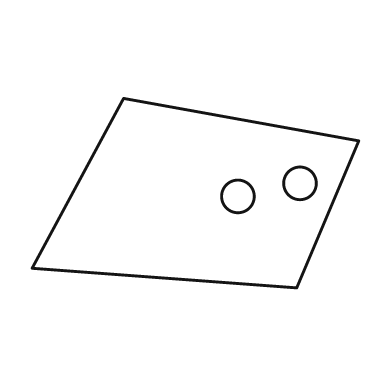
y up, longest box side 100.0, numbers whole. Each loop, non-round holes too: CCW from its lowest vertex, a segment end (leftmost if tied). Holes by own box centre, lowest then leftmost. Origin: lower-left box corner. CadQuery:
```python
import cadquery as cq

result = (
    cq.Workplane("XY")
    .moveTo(81.0, 0.0)
    .lineTo(100.0, 45.0)
    .lineTo(28.0, 58.0)
    .lineTo(0.0, 6.0)
    .close()
    .moveTo(63.0, 28.0)
    .circle(5.0)
    .moveTo(82.0, 32.0)
    .circle(5.0)
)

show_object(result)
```